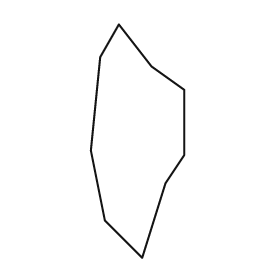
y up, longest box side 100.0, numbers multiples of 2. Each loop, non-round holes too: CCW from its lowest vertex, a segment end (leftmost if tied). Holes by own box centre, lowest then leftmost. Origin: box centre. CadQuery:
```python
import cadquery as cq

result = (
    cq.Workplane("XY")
    .moveTo(2.0, -50.0)
    .lineTo(12.0, -18.0)
    .lineTo(20.0, -6.0)
    .lineTo(20.0, 22.0)
    .lineTo(6.0, 32.0)
    .lineTo(-8.0, 50.0)
    .lineTo(-16.0, 36.0)
    .lineTo(-20.0, -4.0)
    .lineTo(-14.0, -34.0)
    .close()
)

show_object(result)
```